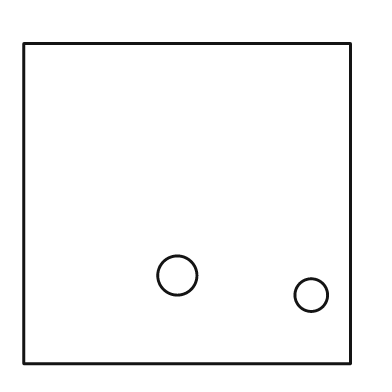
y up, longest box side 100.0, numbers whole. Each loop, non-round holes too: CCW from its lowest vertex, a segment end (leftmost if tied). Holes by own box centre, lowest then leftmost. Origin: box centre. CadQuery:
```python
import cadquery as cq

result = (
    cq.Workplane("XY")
    .moveTo(-50.0, -49.0)
    .lineTo(50.0, -49.0)
    .lineTo(50.0, 49.0)
    .lineTo(-50.0, 49.0)
    .close()
    .moveTo(38.0, -28.0)
    .circle(5.0)
    .moveTo(-3.0, -22.0)
    .circle(6.0)
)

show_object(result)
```